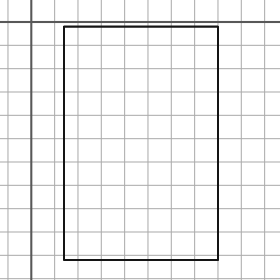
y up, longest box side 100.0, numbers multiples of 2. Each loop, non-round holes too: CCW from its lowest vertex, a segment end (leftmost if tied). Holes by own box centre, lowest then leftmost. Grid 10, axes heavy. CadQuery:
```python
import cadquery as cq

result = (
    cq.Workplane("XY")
    .moveTo(14.0, -102.0)
    .lineTo(80.0, -102.0)
    .lineTo(80.0, -2.0)
    .lineTo(14.0, -2.0)
    .close()
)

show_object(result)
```